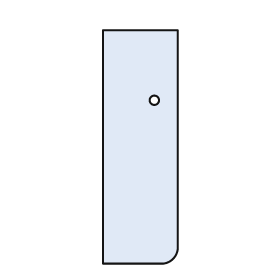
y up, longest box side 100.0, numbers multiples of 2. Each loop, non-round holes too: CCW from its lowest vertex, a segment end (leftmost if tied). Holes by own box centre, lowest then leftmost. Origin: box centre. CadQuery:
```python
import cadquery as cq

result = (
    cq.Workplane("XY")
    .moveTo(-16.0, -50.0)
    .lineTo(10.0, -50.0)
    .threePointArc((14.0, -48.0), (16.0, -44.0))
    .lineTo(16.0, 50.0)
    .lineTo(-16.0, 50.0)
    .close()
    .moveTo(6.0, 20.0)
    .circle(2.0)
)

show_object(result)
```